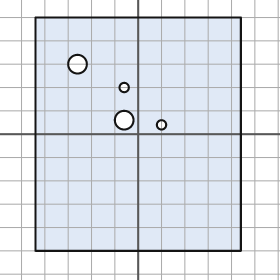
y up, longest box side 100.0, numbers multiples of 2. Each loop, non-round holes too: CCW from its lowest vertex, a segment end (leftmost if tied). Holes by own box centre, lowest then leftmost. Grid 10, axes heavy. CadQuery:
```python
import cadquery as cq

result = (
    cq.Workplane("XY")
    .moveTo(-44.0, -50.0)
    .lineTo(44.0, -50.0)
    .lineTo(44.0, 50.0)
    .lineTo(-44.0, 50.0)
    .close()
    .moveTo(10.0, 4.0)
    .circle(2.0)
    .moveTo(-6.0, 6.0)
    .circle(4.0)
    .moveTo(-6.0, 20.0)
    .circle(2.0)
    .moveTo(-26.0, 30.0)
    .circle(4.0)
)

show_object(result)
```